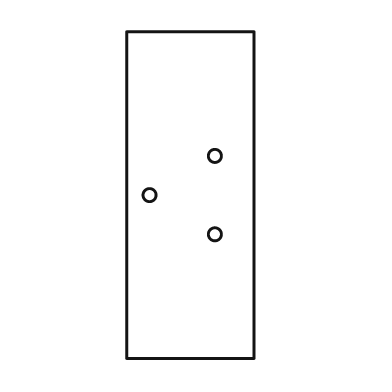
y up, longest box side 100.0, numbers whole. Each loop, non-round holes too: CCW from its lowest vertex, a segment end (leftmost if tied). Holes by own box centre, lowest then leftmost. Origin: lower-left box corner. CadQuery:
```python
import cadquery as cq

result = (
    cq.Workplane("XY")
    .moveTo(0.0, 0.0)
    .lineTo(39.0, 0.0)
    .lineTo(39.0, 100.0)
    .lineTo(0.0, 100.0)
    .close()
    .moveTo(27.0, 38.0)
    .circle(2.0)
    .moveTo(7.0, 50.0)
    .circle(2.0)
    .moveTo(27.0, 62.0)
    .circle(2.0)
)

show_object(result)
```